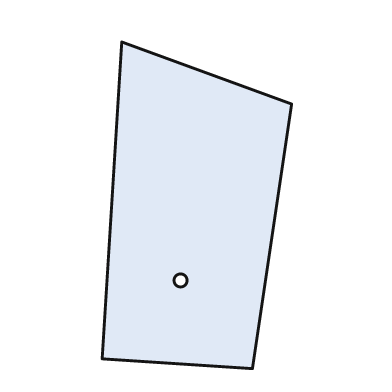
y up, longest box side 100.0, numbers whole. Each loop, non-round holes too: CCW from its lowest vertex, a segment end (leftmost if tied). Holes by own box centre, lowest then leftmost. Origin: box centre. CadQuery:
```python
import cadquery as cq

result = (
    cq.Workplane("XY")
    .moveTo(17.0, -50.0)
    .lineTo(29.0, 31.0)
    .lineTo(-23.0, 50.0)
    .lineTo(-29.0, -47.0)
    .close()
    .moveTo(-5.0, -23.0)
    .circle(2.0)
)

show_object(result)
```